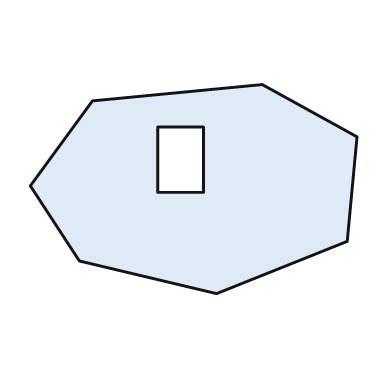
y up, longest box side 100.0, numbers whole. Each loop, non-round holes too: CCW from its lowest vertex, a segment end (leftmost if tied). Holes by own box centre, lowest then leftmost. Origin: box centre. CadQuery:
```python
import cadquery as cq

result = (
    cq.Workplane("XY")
    .moveTo(7.0, -32.0)
    .lineTo(47.0, -16.0)
    .lineTo(50.0, 16.0)
    .lineTo(21.0, 32.0)
    .lineTo(-31.0, 27.0)
    .lineTo(-50.0, 1.0)
    .lineTo(-35.0, -22.0)
    .close()
    .moveTo(-11.0, -1.0)
    .lineTo(3.0, -1.0)
    .lineTo(3.0, 19.0)
    .lineTo(-11.0, 19.0)
    .close()
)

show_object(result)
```